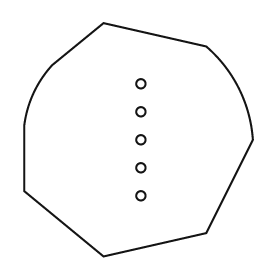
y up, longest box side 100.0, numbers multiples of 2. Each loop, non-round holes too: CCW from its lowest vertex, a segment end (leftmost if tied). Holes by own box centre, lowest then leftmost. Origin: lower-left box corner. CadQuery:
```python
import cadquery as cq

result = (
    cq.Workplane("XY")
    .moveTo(34.0, 0.0)
    .lineTo(78.0, 10.0)
    .lineTo(98.0, 50.0)
    .threePointArc((92.0, 72.0), (78.0, 90.0))
    .lineTo(34.0, 100.0)
    .lineTo(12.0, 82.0)
    .threePointArc((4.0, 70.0), (0.0, 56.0))
    .lineTo(0.0, 28.0)
    .close()
    .moveTo(50.0, 26.0)
    .circle(2.0)
    .moveTo(50.0, 38.0)
    .circle(2.0)
    .moveTo(50.0, 50.0)
    .circle(2.0)
    .moveTo(50.0, 62.0)
    .circle(2.0)
    .moveTo(50.0, 74.0)
    .circle(2.0)
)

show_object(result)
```